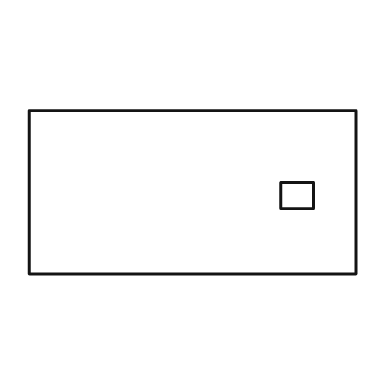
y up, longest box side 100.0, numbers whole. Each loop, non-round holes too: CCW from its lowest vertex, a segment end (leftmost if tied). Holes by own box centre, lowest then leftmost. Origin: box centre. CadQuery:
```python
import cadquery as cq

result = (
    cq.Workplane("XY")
    .moveTo(-50.0, -25.0)
    .lineTo(50.0, -25.0)
    .lineTo(50.0, 25.0)
    .lineTo(-50.0, 25.0)
    .close()
    .moveTo(27.0, -5.0)
    .lineTo(37.0, -5.0)
    .lineTo(37.0, 3.0)
    .lineTo(27.0, 3.0)
    .close()
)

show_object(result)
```